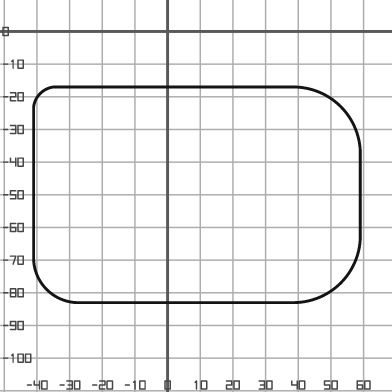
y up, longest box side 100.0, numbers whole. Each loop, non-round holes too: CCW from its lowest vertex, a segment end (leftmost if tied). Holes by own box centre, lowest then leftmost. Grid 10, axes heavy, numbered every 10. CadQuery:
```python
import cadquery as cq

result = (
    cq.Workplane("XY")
    .moveTo(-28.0, -83.0)
    .lineTo(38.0, -83.0)
    .threePointArc((53.0, -77.0), (59.0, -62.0))
    .lineTo(59.0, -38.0)
    .threePointArc((53.0, -23.0), (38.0, -17.0))
    .lineTo(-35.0, -17.0)
    .threePointArc((-39.0, -19.0), (-41.0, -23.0))
    .lineTo(-41.0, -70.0)
    .threePointArc((-37.0, -79.0), (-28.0, -83.0))
    .close()
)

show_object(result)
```